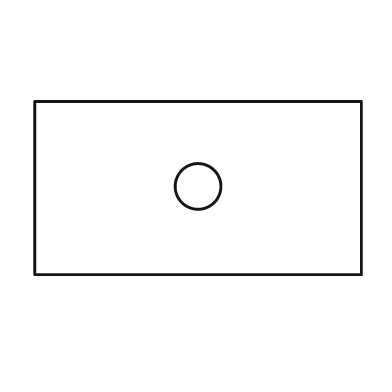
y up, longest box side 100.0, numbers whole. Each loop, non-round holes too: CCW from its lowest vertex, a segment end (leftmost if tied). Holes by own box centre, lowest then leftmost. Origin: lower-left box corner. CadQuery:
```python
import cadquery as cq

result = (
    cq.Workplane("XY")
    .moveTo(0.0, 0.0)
    .lineTo(100.0, 0.0)
    .lineTo(100.0, 53.0)
    .lineTo(0.0, 53.0)
    .close()
    .moveTo(50.0, 27.0)
    .circle(7.0)
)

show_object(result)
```